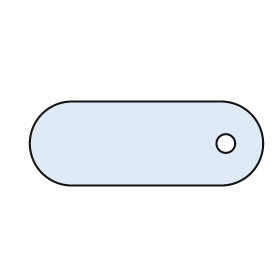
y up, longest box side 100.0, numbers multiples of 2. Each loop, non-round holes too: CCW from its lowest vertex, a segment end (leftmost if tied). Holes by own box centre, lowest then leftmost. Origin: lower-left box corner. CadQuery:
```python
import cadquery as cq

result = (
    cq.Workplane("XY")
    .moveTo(18.0, 0.0)
    .lineTo(82.0, 0.0)
    .threePointArc((100.0, 18.0), (82.0, 36.0))
    .lineTo(18.0, 36.0)
    .threePointArc((0.0, 18.0), (18.0, 0.0))
    .close()
    .moveTo(84.0, 18.0)
    .circle(4.0)
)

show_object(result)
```